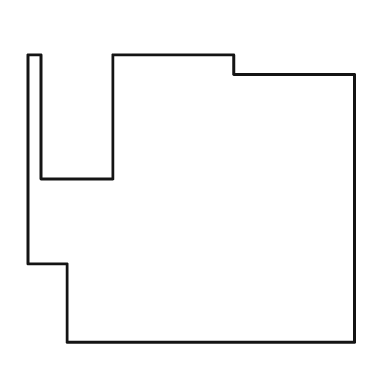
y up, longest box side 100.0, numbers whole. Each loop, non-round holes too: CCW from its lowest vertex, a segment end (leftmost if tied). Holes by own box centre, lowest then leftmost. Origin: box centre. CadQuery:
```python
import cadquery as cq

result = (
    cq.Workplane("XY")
    .moveTo(-38.0, -44.0)
    .lineTo(50.0, -44.0)
    .lineTo(50.0, 38.0)
    .lineTo(13.0, 38.0)
    .lineTo(13.0, 44.0)
    .lineTo(-24.0, 44.0)
    .lineTo(-24.0, 6.0)
    .lineTo(-46.0, 6.0)
    .lineTo(-46.0, 44.0)
    .lineTo(-50.0, 44.0)
    .lineTo(-50.0, -20.0)
    .lineTo(-38.0, -20.0)
    .close()
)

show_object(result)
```